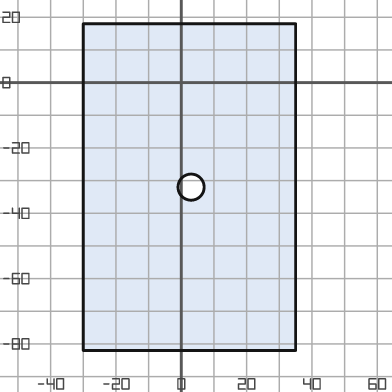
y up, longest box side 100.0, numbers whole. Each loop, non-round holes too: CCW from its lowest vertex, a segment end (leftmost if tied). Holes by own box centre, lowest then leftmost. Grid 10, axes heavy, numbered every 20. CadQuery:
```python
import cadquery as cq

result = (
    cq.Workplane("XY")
    .moveTo(-30.0, -82.0)
    .lineTo(35.0, -82.0)
    .lineTo(35.0, 18.0)
    .lineTo(-30.0, 18.0)
    .close()
    .moveTo(3.0, -32.0)
    .circle(4.0)
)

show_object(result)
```